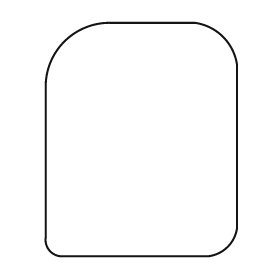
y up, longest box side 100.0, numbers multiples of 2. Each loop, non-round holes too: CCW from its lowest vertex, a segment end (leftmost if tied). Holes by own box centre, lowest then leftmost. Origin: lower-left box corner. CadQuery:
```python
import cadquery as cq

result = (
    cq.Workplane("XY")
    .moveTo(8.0, 0.0)
    .lineTo(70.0, 0.0)
    .threePointArc((78.0, 4.0), (82.0, 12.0))
    .lineTo(82.0, 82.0)
    .threePointArc((76.0, 94.0), (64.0, 100.0))
    .lineTo(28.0, 100.0)
    .threePointArc((8.0, 92.0), (0.0, 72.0))
    .lineTo(0.0, 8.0)
    .threePointArc((2.0, 2.0), (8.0, 0.0))
    .close()
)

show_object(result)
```